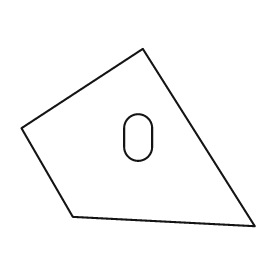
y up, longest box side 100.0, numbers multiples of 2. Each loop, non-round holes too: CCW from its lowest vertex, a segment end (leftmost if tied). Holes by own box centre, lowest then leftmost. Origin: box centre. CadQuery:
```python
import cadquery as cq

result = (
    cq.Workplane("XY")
    .moveTo(50.0, -38.0)
    .lineTo(2.0, 38.0)
    .lineTo(-50.0, 4.0)
    .lineTo(-28.0, -34.0)
    .close()
    .moveTo(-6.0, -4.0)
    .threePointArc((0.0, -10.0), (6.0, -4.0))
    .lineTo(6.0, 4.0)
    .threePointArc((0.0, 10.0), (-6.0, 4.0))
    .close()
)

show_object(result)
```